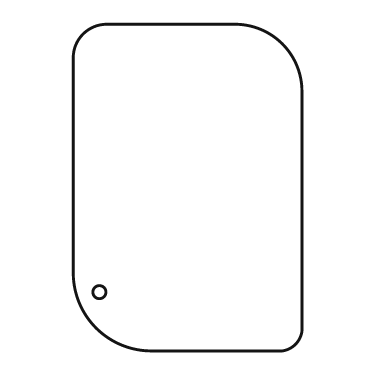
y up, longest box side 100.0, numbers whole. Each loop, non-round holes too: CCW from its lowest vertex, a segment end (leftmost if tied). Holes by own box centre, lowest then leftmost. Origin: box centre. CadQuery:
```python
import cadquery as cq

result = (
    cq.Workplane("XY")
    .moveTo(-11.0, -50.0)
    .lineTo(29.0, -50.0)
    .threePointArc((33.0, -48.0), (35.0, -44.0))
    .lineTo(35.0, 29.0)
    .threePointArc((29.0, 44.0), (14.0, 50.0))
    .lineTo(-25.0, 50.0)
    .threePointArc((-32.0, 47.0), (-35.0, 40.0))
    .lineTo(-35.0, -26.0)
    .threePointArc((-28.0, -43.0), (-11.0, -50.0))
    .close()
    .moveTo(-27.0, -32.0)
    .circle(2.0)
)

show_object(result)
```